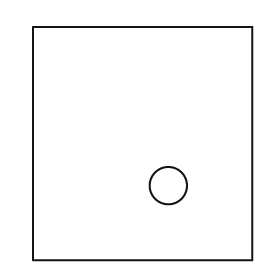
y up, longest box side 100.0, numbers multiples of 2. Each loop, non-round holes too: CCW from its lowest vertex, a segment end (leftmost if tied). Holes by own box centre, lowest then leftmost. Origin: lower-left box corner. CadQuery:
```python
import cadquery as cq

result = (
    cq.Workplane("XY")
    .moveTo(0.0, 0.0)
    .lineTo(94.0, 0.0)
    .lineTo(94.0, 100.0)
    .lineTo(0.0, 100.0)
    .close()
    .moveTo(58.0, 32.0)
    .circle(8.0)
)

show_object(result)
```